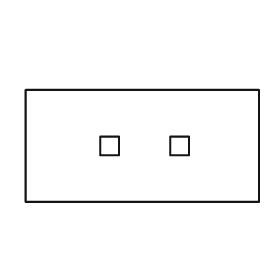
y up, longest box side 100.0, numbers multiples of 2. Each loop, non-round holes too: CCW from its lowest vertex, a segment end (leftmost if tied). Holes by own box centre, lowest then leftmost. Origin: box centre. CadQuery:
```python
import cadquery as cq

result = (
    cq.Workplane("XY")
    .moveTo(-50.0, -24.0)
    .lineTo(50.0, -24.0)
    .lineTo(50.0, 24.0)
    .lineTo(-50.0, 24.0)
    .close()
    .moveTo(-18.0, -4.0)
    .lineTo(-10.0, -4.0)
    .lineTo(-10.0, 4.0)
    .lineTo(-18.0, 4.0)
    .close()
    .moveTo(12.0, -4.0)
    .lineTo(20.0, -4.0)
    .lineTo(20.0, 4.0)
    .lineTo(12.0, 4.0)
    .close()
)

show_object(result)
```